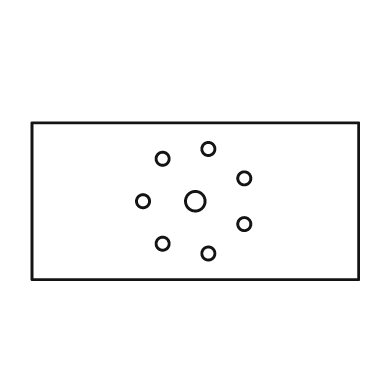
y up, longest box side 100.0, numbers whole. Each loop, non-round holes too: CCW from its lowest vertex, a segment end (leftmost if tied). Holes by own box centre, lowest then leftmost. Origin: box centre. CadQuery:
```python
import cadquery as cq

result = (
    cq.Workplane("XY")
    .moveTo(-50.0, -24.0)
    .lineTo(50.0, -24.0)
    .lineTo(50.0, 24.0)
    .lineTo(-50.0, 24.0)
    .close()
    .moveTo(4.0, -16.0)
    .circle(2.0)
    .moveTo(-10.0, -13.0)
    .circle(2.0)
    .moveTo(15.0, -7.0)
    .circle(2.0)
    .moveTo(-16.0, 0.0)
    .circle(2.0)
    .moveTo(0.0, 0.0)
    .circle(3.0)
    .moveTo(15.0, 7.0)
    .circle(2.0)
    .moveTo(-10.0, 13.0)
    .circle(2.0)
    .moveTo(4.0, 16.0)
    .circle(2.0)
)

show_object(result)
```